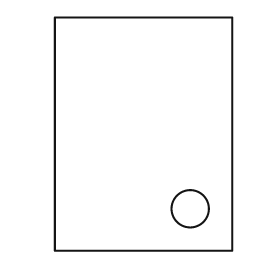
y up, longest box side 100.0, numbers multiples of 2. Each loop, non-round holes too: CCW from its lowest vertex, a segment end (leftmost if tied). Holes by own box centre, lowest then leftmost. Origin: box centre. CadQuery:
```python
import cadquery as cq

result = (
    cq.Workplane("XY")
    .moveTo(-38.0, -50.0)
    .lineTo(38.0, -50.0)
    .lineTo(38.0, 50.0)
    .lineTo(-38.0, 50.0)
    .close()
    .moveTo(20.0, -32.0)
    .circle(8.0)
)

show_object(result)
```